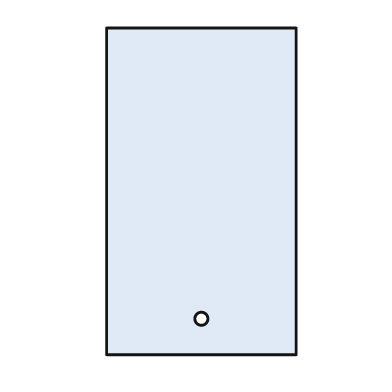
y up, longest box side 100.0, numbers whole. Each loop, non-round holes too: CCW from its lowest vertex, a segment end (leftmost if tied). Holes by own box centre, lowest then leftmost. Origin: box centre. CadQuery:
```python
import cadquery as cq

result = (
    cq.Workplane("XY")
    .moveTo(-29.0, -50.0)
    .lineTo(29.0, -50.0)
    .lineTo(29.0, 50.0)
    .lineTo(-29.0, 50.0)
    .close()
    .moveTo(0.0, -39.0)
    .circle(2.0)
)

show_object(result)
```